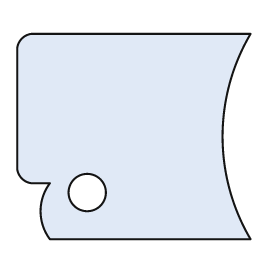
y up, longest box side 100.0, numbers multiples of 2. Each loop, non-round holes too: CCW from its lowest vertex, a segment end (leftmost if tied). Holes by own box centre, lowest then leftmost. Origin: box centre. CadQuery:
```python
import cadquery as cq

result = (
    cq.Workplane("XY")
    .moveTo(-36.0, -44.0)
    .lineTo(50.0, -44.0)
    .threePointArc((38.0, 0.0), (50.0, 44.0))
    .lineTo(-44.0, 44.0)
    .threePointArc((-48.0, 42.0), (-50.0, 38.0))
    .lineTo(-50.0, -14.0)
    .threePointArc((-48.0, -18.0), (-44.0, -20.0))
    .lineTo(-36.0, -20.0)
    .threePointArc((-40.0, -32.0), (-36.0, -44.0))
    .close()
    .moveTo(-20.0, -24.0)
    .circle(8.0)
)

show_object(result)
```